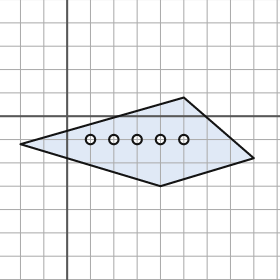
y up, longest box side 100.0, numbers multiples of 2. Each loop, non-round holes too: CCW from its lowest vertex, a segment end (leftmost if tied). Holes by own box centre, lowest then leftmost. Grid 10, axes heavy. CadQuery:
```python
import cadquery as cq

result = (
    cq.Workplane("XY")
    .moveTo(40.0, -30.0)
    .lineTo(80.0, -18.0)
    .lineTo(50.0, 8.0)
    .lineTo(-20.0, -12.0)
    .close()
    .moveTo(10.0, -10.0)
    .circle(2.0)
    .moveTo(20.0, -10.0)
    .circle(2.0)
    .moveTo(30.0, -10.0)
    .circle(2.0)
    .moveTo(40.0, -10.0)
    .circle(2.0)
    .moveTo(50.0, -10.0)
    .circle(2.0)
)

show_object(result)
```